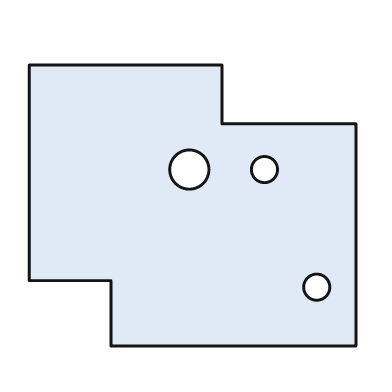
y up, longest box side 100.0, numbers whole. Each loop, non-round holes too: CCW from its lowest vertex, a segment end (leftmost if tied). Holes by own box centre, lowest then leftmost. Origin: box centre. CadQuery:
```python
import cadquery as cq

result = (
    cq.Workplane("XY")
    .moveTo(-25.0, -43.0)
    .lineTo(50.0, -43.0)
    .lineTo(50.0, 25.0)
    .lineTo(9.0, 25.0)
    .lineTo(9.0, 43.0)
    .lineTo(-50.0, 43.0)
    .lineTo(-50.0, -23.0)
    .lineTo(-25.0, -23.0)
    .close()
    .moveTo(38.0, -25.0)
    .circle(4.0)
    .moveTo(-1.0, 11.0)
    .circle(6.0)
    .moveTo(22.0, 11.0)
    .circle(4.0)
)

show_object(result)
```